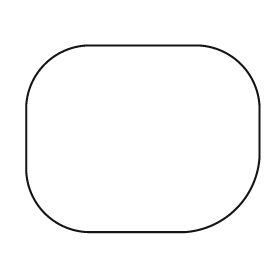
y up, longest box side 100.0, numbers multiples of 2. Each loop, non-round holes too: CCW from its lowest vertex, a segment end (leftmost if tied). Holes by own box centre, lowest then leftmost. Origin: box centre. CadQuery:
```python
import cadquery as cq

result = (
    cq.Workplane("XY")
    .moveTo(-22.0, -40.0)
    .lineTo(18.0, -40.0)
    .threePointArc((40.0, -30.0), (50.0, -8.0))
    .lineTo(50.0, 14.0)
    .threePointArc((42.0, 32.0), (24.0, 40.0))
    .lineTo(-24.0, 40.0)
    .threePointArc((-42.0, 32.0), (-50.0, 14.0))
    .lineTo(-50.0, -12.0)
    .threePointArc((-42.0, -32.0), (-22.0, -40.0))
    .close()
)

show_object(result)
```